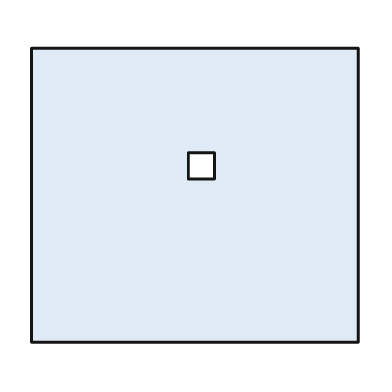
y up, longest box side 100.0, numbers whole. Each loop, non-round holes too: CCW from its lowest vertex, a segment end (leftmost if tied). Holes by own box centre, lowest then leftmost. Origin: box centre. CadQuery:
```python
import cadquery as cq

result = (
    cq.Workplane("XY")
    .moveTo(-50.0, -45.0)
    .lineTo(50.0, -45.0)
    .lineTo(50.0, 45.0)
    .lineTo(-50.0, 45.0)
    .close()
    .moveTo(-2.0, 5.0)
    .lineTo(6.0, 5.0)
    .lineTo(6.0, 13.0)
    .lineTo(-2.0, 13.0)
    .close()
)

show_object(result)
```